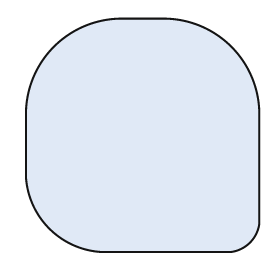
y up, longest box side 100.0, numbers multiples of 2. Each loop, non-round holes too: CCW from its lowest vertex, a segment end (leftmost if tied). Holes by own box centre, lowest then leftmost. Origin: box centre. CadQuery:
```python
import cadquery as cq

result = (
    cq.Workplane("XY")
    .moveTo(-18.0, -50.0)
    .lineTo(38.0, -50.0)
    .threePointArc((46.0, -46.0), (50.0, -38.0))
    .lineTo(50.0, 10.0)
    .threePointArc((38.0, 38.0), (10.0, 50.0))
    .lineTo(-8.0, 50.0)
    .threePointArc((-38.0, 38.0), (-50.0, 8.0))
    .lineTo(-50.0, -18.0)
    .threePointArc((-40.0, -40.0), (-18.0, -50.0))
    .close()
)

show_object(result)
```